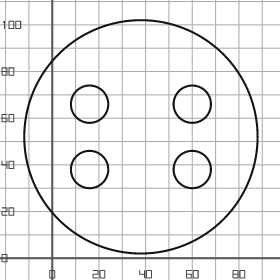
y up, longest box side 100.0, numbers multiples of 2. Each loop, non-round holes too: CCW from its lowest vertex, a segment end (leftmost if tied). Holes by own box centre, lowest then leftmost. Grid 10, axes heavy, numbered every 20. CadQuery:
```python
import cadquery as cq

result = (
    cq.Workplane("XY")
    .moveTo(38.0, 52.0)
    .circle(50.0)
    .moveTo(16.0, 38.0)
    .circle(8.0)
    .moveTo(60.0, 38.0)
    .circle(8.0)
    .moveTo(16.0, 66.0)
    .circle(8.0)
    .moveTo(60.0, 66.0)
    .circle(8.0)
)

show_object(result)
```